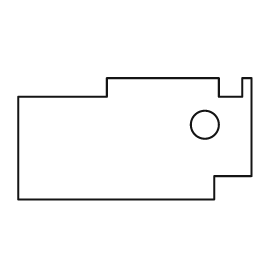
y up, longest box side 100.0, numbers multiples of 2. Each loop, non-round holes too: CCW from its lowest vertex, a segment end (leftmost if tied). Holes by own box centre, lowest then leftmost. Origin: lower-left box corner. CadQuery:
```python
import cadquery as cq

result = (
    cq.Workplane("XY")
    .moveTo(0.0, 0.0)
    .lineTo(84.0, 0.0)
    .lineTo(84.0, 10.0)
    .lineTo(100.0, 10.0)
    .lineTo(100.0, 52.0)
    .lineTo(96.0, 52.0)
    .lineTo(96.0, 44.0)
    .lineTo(86.0, 44.0)
    .lineTo(86.0, 52.0)
    .lineTo(38.0, 52.0)
    .lineTo(38.0, 44.0)
    .lineTo(0.0, 44.0)
    .close()
    .moveTo(80.0, 32.0)
    .circle(6.0)
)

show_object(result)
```